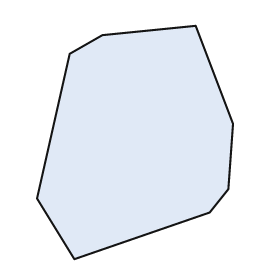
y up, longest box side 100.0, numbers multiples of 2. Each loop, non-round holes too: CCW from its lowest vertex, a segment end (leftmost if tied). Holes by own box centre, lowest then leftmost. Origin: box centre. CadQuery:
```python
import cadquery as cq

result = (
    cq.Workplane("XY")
    .moveTo(-26.0, -50.0)
    .lineTo(32.0, -30.0)
    .lineTo(40.0, -20.0)
    .lineTo(42.0, 8.0)
    .lineTo(26.0, 50.0)
    .lineTo(-14.0, 46.0)
    .lineTo(-28.0, 38.0)
    .lineTo(-42.0, -24.0)
    .close()
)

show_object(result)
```